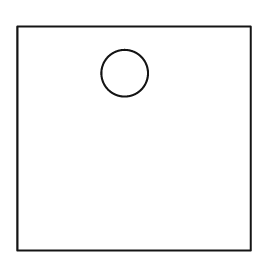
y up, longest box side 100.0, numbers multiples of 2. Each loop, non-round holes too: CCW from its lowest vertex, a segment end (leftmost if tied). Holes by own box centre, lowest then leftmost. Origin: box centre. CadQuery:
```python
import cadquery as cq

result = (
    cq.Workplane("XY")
    .moveTo(-50.0, -48.0)
    .lineTo(50.0, -48.0)
    .lineTo(50.0, 48.0)
    .lineTo(-50.0, 48.0)
    .close()
    .moveTo(-4.0, 28.0)
    .circle(10.0)
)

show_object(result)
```